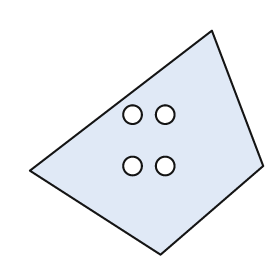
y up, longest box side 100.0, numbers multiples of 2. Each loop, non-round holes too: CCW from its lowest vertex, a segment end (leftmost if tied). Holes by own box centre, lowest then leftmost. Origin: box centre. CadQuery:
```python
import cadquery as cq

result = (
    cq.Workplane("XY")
    .moveTo(6.0, -48.0)
    .lineTo(50.0, -10.0)
    .lineTo(28.0, 48.0)
    .lineTo(-50.0, -12.0)
    .close()
    .moveTo(-6.0, -10.0)
    .circle(4.0)
    .moveTo(8.0, -10.0)
    .circle(4.0)
    .moveTo(-6.0, 12.0)
    .circle(4.0)
    .moveTo(8.0, 12.0)
    .circle(4.0)
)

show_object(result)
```